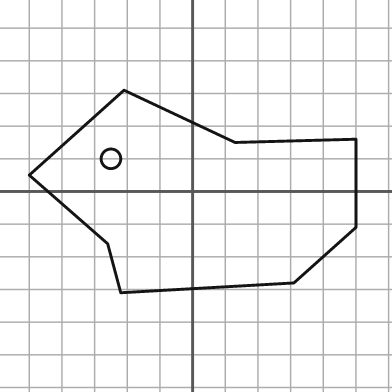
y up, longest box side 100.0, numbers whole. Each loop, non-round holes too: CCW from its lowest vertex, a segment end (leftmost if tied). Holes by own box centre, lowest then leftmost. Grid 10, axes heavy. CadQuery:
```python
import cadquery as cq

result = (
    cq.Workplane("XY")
    .moveTo(-22.0, -31.0)
    .lineTo(31.0, -28.0)
    .lineTo(50.0, -11.0)
    .lineTo(50.0, 16.0)
    .lineTo(13.0, 15.0)
    .lineTo(-21.0, 31.0)
    .lineTo(-50.0, 5.0)
    .lineTo(-26.0, -16.0)
    .close()
    .moveTo(-25.0, 10.0)
    .circle(3.0)
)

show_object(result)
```